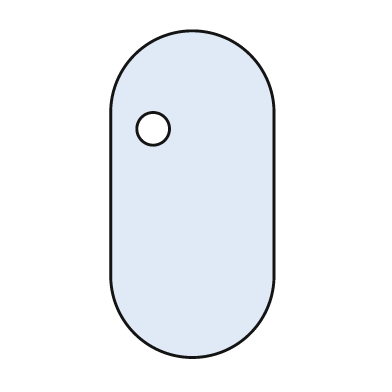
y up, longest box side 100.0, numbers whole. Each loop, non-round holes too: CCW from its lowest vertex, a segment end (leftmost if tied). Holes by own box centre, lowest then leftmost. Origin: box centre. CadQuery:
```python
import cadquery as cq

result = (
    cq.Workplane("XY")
    .moveTo(-25.0, -25.0)
    .threePointArc((0.0, -50.0), (25.0, -25.0))
    .lineTo(25.0, 25.0)
    .threePointArc((0.0, 50.0), (-25.0, 25.0))
    .close()
    .moveTo(-12.0, 20.0)
    .circle(5.0)
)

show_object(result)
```